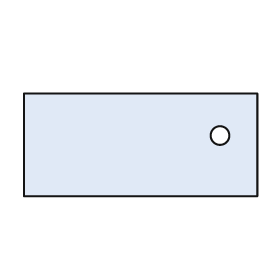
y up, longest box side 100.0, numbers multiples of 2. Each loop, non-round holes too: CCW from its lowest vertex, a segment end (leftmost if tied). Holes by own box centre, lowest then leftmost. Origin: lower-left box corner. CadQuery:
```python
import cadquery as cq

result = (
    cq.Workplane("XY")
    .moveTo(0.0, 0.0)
    .lineTo(100.0, 0.0)
    .lineTo(100.0, 44.0)
    .lineTo(0.0, 44.0)
    .close()
    .moveTo(84.0, 26.0)
    .circle(4.0)
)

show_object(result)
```